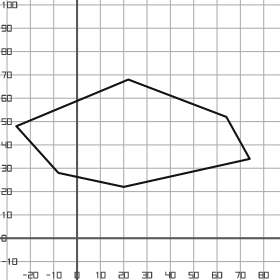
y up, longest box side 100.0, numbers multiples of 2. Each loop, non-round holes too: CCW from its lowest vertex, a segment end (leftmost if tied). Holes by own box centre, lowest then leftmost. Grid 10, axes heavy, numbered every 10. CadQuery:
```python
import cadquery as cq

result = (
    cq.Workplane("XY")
    .moveTo(20.0, 22.0)
    .lineTo(74.0, 34.0)
    .lineTo(64.0, 52.0)
    .lineTo(22.0, 68.0)
    .lineTo(-26.0, 48.0)
    .lineTo(-8.0, 28.0)
    .close()
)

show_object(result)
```